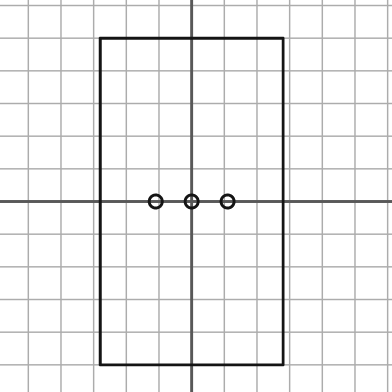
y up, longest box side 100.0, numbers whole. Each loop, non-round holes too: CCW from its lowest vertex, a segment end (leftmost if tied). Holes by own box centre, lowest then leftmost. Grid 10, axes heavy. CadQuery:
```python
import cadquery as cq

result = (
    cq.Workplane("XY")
    .moveTo(-28.0, -50.0)
    .lineTo(28.0, -50.0)
    .lineTo(28.0, 50.0)
    .lineTo(-28.0, 50.0)
    .close()
    .moveTo(-11.0, 0.0)
    .circle(2.0)
    .moveTo(0.0, 0.0)
    .circle(2.0)
    .moveTo(11.0, 0.0)
    .circle(2.0)
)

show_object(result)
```